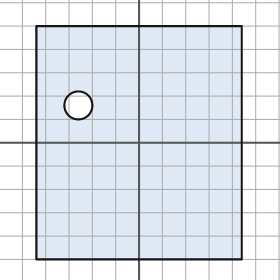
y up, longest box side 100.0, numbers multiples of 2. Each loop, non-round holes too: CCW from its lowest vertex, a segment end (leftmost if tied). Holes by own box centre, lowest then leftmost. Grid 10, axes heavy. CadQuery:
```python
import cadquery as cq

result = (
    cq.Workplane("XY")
    .moveTo(-44.0, -50.0)
    .lineTo(44.0, -50.0)
    .lineTo(44.0, 50.0)
    .lineTo(-44.0, 50.0)
    .close()
    .moveTo(-26.0, 16.0)
    .circle(6.0)
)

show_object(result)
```